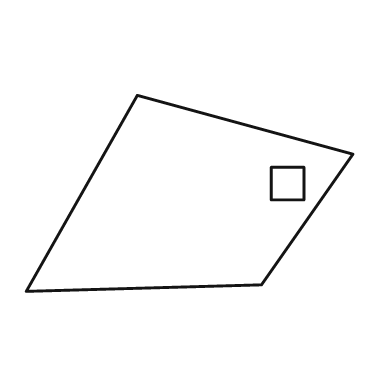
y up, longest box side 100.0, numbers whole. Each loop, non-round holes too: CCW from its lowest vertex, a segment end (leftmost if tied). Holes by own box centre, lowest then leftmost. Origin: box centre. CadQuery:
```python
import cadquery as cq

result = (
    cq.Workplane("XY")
    .moveTo(-50.0, -30.0)
    .lineTo(22.0, -28.0)
    .lineTo(50.0, 12.0)
    .lineTo(-16.0, 30.0)
    .close()
    .moveTo(25.0, -2.0)
    .lineTo(35.0, -2.0)
    .lineTo(35.0, 8.0)
    .lineTo(25.0, 8.0)
    .close()
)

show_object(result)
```